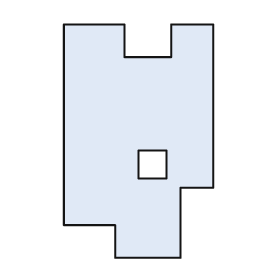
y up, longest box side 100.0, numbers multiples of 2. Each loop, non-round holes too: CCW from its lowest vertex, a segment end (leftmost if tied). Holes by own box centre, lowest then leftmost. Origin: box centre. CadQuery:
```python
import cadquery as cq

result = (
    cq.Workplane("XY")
    .moveTo(-10.0, -50.0)
    .lineTo(18.0, -50.0)
    .lineTo(18.0, -20.0)
    .lineTo(32.0, -20.0)
    .lineTo(32.0, 50.0)
    .lineTo(14.0, 50.0)
    .lineTo(14.0, 36.0)
    .lineTo(-6.0, 36.0)
    .lineTo(-6.0, 50.0)
    .lineTo(-32.0, 50.0)
    .lineTo(-32.0, -36.0)
    .lineTo(-10.0, -36.0)
    .close()
    .moveTo(0.0, -16.0)
    .lineTo(12.0, -16.0)
    .lineTo(12.0, -4.0)
    .lineTo(0.0, -4.0)
    .close()
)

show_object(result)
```